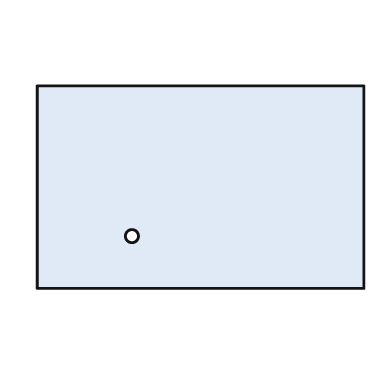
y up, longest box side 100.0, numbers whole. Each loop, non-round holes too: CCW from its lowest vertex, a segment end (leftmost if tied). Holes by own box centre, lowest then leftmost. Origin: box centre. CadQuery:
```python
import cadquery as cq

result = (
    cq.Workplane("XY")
    .moveTo(-50.0, -31.0)
    .lineTo(50.0, -31.0)
    .lineTo(50.0, 31.0)
    .lineTo(-50.0, 31.0)
    .close()
    .moveTo(-21.0, -15.0)
    .circle(2.0)
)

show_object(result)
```